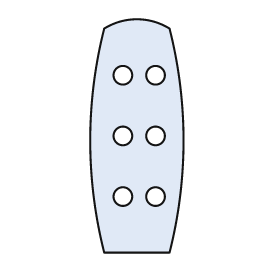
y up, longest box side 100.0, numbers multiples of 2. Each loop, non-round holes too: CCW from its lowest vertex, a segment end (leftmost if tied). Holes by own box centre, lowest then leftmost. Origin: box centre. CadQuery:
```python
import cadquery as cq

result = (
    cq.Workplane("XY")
    .moveTo(-14.0, -50.0)
    .lineTo(14.0, -50.0)
    .threePointArc((20.0, -2.0), (14.0, 46.0))
    .threePointArc((0.0, 50.0), (-14.0, 46.0))
    .threePointArc((-20.0, -2.0), (-14.0, -50.0))
    .close()
    .moveTo(-6.0, -26.0)
    .circle(4.0)
    .moveTo(8.0, -26.0)
    .circle(4.0)
    .moveTo(-6.0, 0.0)
    .circle(4.0)
    .moveTo(8.0, 0.0)
    .circle(4.0)
    .moveTo(-6.0, 26.0)
    .circle(4.0)
    .moveTo(8.0, 26.0)
    .circle(4.0)
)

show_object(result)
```